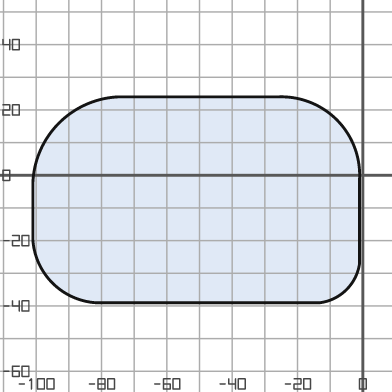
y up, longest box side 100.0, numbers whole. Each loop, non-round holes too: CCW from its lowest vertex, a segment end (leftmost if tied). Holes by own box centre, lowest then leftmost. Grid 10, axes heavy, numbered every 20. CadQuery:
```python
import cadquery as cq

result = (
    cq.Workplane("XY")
    .moveTo(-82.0, -39.0)
    .lineTo(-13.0, -39.0)
    .threePointArc((-5.0, -35.0), (-1.0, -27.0))
    .lineTo(-1.0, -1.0)
    .threePointArc((-8.0, 17.0), (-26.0, 24.0))
    .lineTo(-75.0, 24.0)
    .threePointArc((-93.0, 16.0), (-101.0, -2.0))
    .lineTo(-101.0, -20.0)
    .threePointArc((-95.0, -33.0), (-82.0, -39.0))
    .close()
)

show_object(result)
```